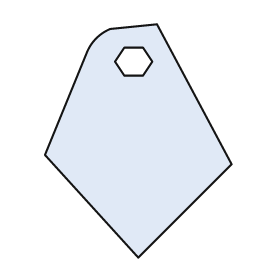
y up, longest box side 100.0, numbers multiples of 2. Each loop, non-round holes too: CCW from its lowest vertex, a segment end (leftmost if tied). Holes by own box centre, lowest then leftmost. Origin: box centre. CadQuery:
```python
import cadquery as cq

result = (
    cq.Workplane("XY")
    .moveTo(0.0, -50.0)
    .lineTo(40.0, -10.0)
    .lineTo(8.0, 50.0)
    .lineTo(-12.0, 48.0)
    .threePointArc((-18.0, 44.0), (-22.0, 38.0))
    .lineTo(-40.0, -6.0)
    .close()
    .moveTo(-6.0, 28.0)
    .lineTo(2.0, 28.0)
    .lineTo(6.0, 34.0)
    .lineTo(2.0, 40.0)
    .lineTo(-6.0, 40.0)
    .lineTo(-10.0, 34.0)
    .close()
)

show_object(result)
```